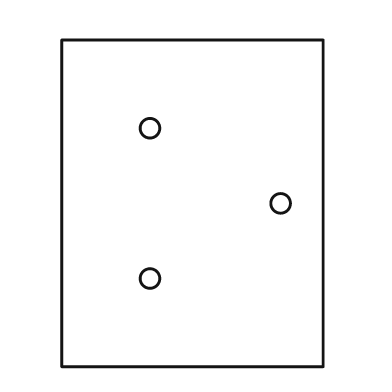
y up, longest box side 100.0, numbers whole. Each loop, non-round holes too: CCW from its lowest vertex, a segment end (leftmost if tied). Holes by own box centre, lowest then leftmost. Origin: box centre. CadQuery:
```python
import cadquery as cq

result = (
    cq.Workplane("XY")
    .moveTo(-40.0, -50.0)
    .lineTo(40.0, -50.0)
    .lineTo(40.0, 50.0)
    .lineTo(-40.0, 50.0)
    .close()
    .moveTo(-13.0, -23.0)
    .circle(3.0)
    .moveTo(27.0, 0.0)
    .circle(3.0)
    .moveTo(-13.0, 23.0)
    .circle(3.0)
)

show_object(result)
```